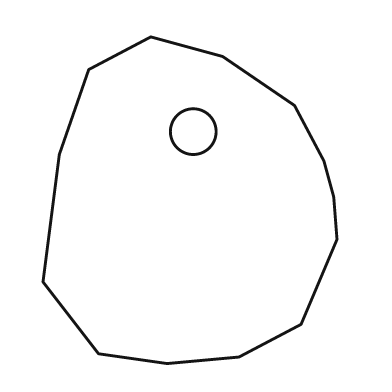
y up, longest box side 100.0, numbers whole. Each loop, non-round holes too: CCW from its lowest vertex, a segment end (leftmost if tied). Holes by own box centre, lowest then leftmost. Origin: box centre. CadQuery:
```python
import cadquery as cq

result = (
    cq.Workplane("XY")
    .moveTo(-7.0, -50.0)
    .lineTo(15.0, -48.0)
    .lineTo(34.0, -38.0)
    .lineTo(45.0, -12.0)
    .lineTo(44.0, 1.0)
    .lineTo(41.0, 12.0)
    .lineTo(32.0, 29.0)
    .lineTo(10.0, 44.0)
    .lineTo(-12.0, 50.0)
    .lineTo(-31.0, 40.0)
    .lineTo(-40.0, 14.0)
    .lineTo(-45.0, -25.0)
    .lineTo(-28.0, -47.0)
    .close()
    .moveTo(1.0, 21.0)
    .circle(7.0)
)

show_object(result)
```